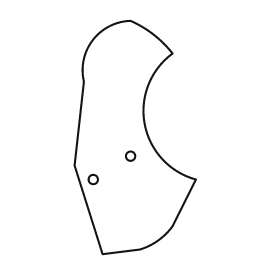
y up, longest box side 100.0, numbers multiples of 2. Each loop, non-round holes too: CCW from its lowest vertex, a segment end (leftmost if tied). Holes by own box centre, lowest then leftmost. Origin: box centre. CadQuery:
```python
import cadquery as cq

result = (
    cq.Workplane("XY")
    .moveTo(-14.0, -50.0)
    .lineTo(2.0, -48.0)
    .threePointArc((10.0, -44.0), (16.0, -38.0))
    .lineTo(26.0, -18.0)
    .threePointArc((4.0, 6.0), (16.0, 36.0))
    .threePointArc((8.0, 44.0), (-2.0, 50.0))
    .threePointArc((-18.0, 42.0), (-22.0, 24.0))
    .lineTo(-26.0, -12.0)
    .close()
    .moveTo(-18.0, -18.0)
    .circle(2.0)
    .moveTo(-2.0, -8.0)
    .circle(2.0)
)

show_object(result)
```